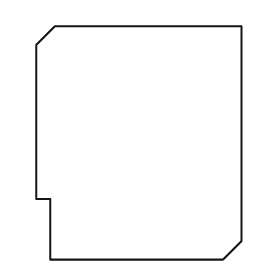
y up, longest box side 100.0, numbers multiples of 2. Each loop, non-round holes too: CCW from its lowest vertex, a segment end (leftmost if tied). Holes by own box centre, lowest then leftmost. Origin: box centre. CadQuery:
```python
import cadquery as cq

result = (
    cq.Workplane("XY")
    .moveTo(-38.0, -50.0)
    .lineTo(36.0, -50.0)
    .lineTo(44.0, -42.0)
    .lineTo(44.0, 50.0)
    .lineTo(-36.0, 50.0)
    .lineTo(-44.0, 42.0)
    .lineTo(-44.0, -24.0)
    .lineTo(-38.0, -24.0)
    .close()
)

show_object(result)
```